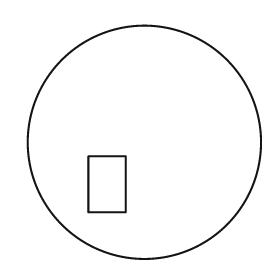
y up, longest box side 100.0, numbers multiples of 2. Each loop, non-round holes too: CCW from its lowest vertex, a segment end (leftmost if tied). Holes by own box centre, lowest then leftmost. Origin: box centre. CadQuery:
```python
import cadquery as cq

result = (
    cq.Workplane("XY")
    .moveTo(0.0, 0.0)
    .circle(50.0)
    .moveTo(-24.0, -30.0)
    .lineTo(-8.0, -30.0)
    .lineTo(-8.0, -6.0)
    .lineTo(-24.0, -6.0)
    .close()
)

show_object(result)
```